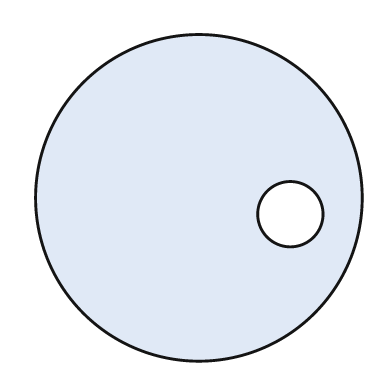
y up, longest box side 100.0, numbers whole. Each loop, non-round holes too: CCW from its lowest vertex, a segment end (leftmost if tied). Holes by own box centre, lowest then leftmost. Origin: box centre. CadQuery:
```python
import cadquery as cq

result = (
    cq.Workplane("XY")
    .moveTo(0.0, 0.0)
    .circle(50.0)
    .moveTo(28.0, -5.0)
    .circle(10.0)
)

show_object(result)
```